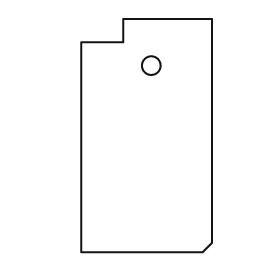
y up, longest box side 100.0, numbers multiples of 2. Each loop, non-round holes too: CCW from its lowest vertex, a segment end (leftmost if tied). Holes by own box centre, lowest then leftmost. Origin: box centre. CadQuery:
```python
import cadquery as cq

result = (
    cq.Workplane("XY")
    .moveTo(-28.0, -50.0)
    .lineTo(24.0, -50.0)
    .lineTo(28.0, -46.0)
    .lineTo(28.0, 50.0)
    .lineTo(-10.0, 50.0)
    .lineTo(-10.0, 40.0)
    .lineTo(-28.0, 40.0)
    .close()
    .moveTo(2.0, 30.0)
    .circle(4.0)
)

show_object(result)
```